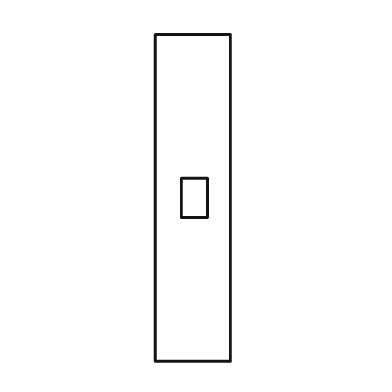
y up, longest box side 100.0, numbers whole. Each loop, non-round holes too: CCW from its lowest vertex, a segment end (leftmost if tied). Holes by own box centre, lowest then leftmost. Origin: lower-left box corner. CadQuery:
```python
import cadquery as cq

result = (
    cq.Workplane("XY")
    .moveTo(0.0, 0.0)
    .lineTo(23.0, 0.0)
    .lineTo(23.0, 100.0)
    .lineTo(0.0, 100.0)
    .close()
    .moveTo(8.0, 44.0)
    .lineTo(16.0, 44.0)
    .lineTo(16.0, 56.0)
    .lineTo(8.0, 56.0)
    .close()
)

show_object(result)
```